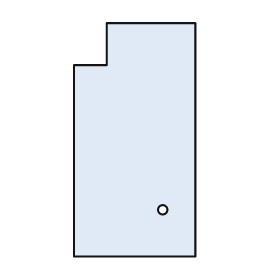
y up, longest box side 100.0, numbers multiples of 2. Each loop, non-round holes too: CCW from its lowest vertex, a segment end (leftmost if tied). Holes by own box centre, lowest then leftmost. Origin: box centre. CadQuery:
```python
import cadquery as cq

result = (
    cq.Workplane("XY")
    .moveTo(-26.0, -50.0)
    .lineTo(26.0, -50.0)
    .lineTo(26.0, 50.0)
    .lineTo(-12.0, 50.0)
    .lineTo(-12.0, 32.0)
    .lineTo(-26.0, 32.0)
    .close()
    .moveTo(12.0, -30.0)
    .circle(2.0)
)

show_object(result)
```